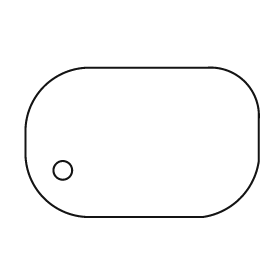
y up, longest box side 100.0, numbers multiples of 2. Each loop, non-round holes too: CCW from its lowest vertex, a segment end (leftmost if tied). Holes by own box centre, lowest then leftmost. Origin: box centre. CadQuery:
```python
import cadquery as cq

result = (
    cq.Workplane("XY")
    .moveTo(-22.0, -32.0)
    .lineTo(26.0, -32.0)
    .threePointArc((42.0, -24.0), (50.0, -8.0))
    .lineTo(50.0, 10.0)
    .threePointArc((44.0, 26.0), (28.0, 32.0))
    .lineTo(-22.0, 32.0)
    .threePointArc((-42.0, 24.0), (-50.0, 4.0))
    .lineTo(-50.0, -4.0)
    .threePointArc((-42.0, -24.0), (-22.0, -32.0))
    .close()
    .moveTo(-34.0, -12.0)
    .circle(4.0)
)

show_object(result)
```